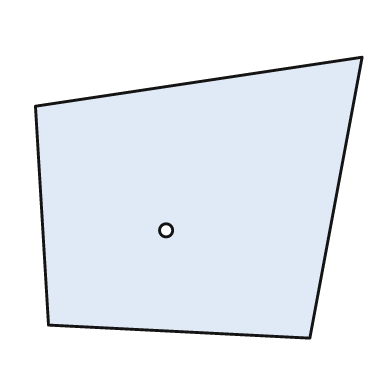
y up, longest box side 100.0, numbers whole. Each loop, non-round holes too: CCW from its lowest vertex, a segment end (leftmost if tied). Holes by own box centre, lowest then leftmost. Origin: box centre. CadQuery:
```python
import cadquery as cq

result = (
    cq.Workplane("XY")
    .moveTo(34.0, -43.0)
    .lineTo(50.0, 43.0)
    .lineTo(-50.0, 28.0)
    .lineTo(-46.0, -39.0)
    .close()
    .moveTo(-10.0, -10.0)
    .circle(2.0)
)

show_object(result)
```